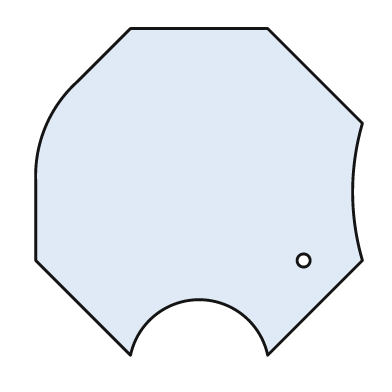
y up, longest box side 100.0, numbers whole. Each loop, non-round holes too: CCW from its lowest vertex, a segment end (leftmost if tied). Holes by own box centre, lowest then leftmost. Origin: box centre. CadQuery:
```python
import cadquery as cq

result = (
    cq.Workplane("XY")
    .moveTo(-21.0, -50.0)
    .threePointArc((0.0, -33.0), (21.0, -50.0))
    .lineTo(50.0, -21.0)
    .threePointArc((47.0, 0.0), (50.0, 21.0))
    .lineTo(21.0, 50.0)
    .lineTo(-21.0, 50.0)
    .lineTo(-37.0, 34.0)
    .threePointArc((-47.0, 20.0), (-50.0, 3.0))
    .lineTo(-50.0, -21.0)
    .close()
    .moveTo(32.0, -21.0)
    .circle(2.0)
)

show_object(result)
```